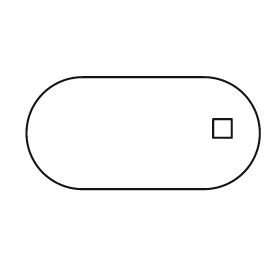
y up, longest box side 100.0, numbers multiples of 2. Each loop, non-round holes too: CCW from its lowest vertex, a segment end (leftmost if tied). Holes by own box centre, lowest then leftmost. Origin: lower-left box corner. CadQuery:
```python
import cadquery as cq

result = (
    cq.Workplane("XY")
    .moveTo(24.0, 0.0)
    .lineTo(76.0, 0.0)
    .threePointArc((100.0, 24.0), (76.0, 48.0))
    .lineTo(24.0, 48.0)
    .threePointArc((0.0, 24.0), (24.0, 0.0))
    .close()
    .moveTo(80.0, 22.0)
    .lineTo(88.0, 22.0)
    .lineTo(88.0, 30.0)
    .lineTo(80.0, 30.0)
    .close()
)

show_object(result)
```